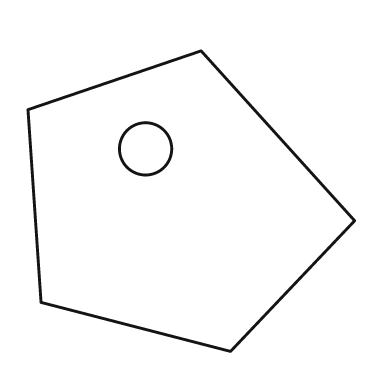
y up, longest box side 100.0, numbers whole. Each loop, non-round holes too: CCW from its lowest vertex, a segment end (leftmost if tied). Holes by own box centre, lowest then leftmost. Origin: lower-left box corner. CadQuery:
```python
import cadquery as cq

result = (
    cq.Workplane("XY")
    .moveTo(62.0, 0.0)
    .lineTo(100.0, 40.0)
    .lineTo(53.0, 92.0)
    .lineTo(0.0, 74.0)
    .lineTo(4.0, 15.0)
    .close()
    .moveTo(36.0, 62.0)
    .circle(8.0)
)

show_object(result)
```